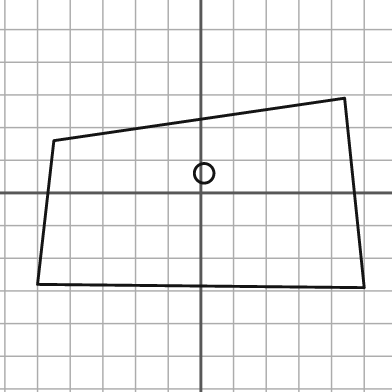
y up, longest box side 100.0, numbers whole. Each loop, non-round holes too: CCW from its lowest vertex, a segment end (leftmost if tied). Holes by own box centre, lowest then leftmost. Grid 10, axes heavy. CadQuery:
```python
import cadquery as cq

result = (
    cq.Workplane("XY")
    .moveTo(50.0, -29.0)
    .lineTo(44.0, 29.0)
    .lineTo(-45.0, 16.0)
    .lineTo(-50.0, -28.0)
    .close()
    .moveTo(1.0, 6.0)
    .circle(3.0)
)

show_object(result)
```